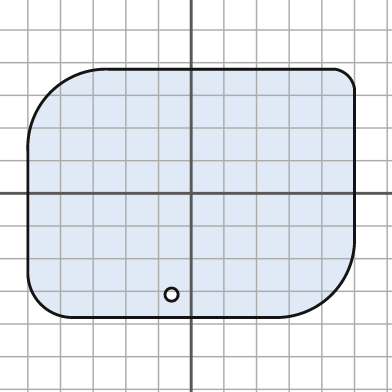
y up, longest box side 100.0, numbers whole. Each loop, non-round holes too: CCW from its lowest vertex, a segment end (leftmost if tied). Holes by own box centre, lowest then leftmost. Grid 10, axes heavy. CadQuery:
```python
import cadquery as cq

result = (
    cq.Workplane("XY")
    .moveTo(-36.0, -38.0)
    .lineTo(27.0, -38.0)
    .threePointArc((43.0, -31.0), (50.0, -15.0))
    .lineTo(50.0, 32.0)
    .threePointArc((48.0, 36.0), (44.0, 38.0))
    .lineTo(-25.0, 38.0)
    .threePointArc((-43.0, 31.0), (-50.0, 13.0))
    .lineTo(-50.0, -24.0)
    .threePointArc((-46.0, -34.0), (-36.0, -38.0))
    .close()
    .moveTo(-6.0, -31.0)
    .circle(2.0)
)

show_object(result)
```